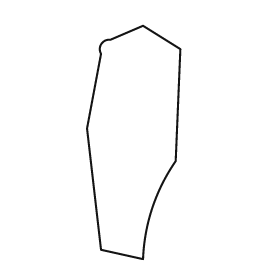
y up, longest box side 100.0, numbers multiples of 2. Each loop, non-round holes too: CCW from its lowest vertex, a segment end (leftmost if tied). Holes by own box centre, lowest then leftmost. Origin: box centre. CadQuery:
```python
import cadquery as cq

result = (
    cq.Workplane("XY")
    .moveTo(4.0, -50.0)
    .threePointArc((8.0, -28.0), (18.0, -8.0))
    .lineTo(20.0, 40.0)
    .lineTo(4.0, 50.0)
    .lineTo(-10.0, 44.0)
    .threePointArc((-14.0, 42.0), (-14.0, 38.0))
    .lineTo(-20.0, 6.0)
    .lineTo(-14.0, -46.0)
    .close()
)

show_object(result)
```